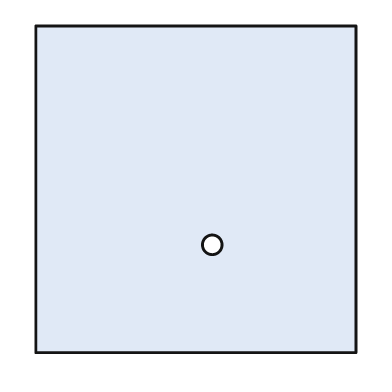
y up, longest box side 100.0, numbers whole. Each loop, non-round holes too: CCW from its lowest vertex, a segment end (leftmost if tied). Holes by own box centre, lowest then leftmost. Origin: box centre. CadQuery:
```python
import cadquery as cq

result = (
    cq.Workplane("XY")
    .moveTo(-49.0, -50.0)
    .lineTo(49.0, -50.0)
    .lineTo(49.0, 50.0)
    .lineTo(-49.0, 50.0)
    .close()
    .moveTo(5.0, -17.0)
    .circle(3.0)
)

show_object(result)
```